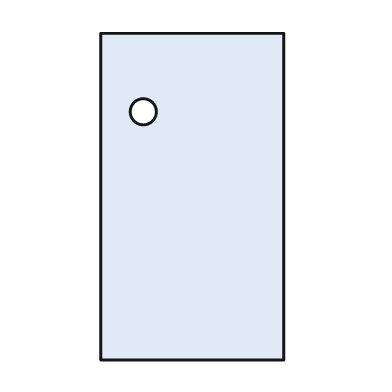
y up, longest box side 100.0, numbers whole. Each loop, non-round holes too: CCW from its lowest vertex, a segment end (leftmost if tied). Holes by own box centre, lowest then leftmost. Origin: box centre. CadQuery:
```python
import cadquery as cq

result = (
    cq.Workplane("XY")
    .moveTo(-28.0, -50.0)
    .lineTo(28.0, -50.0)
    .lineTo(28.0, 50.0)
    .lineTo(-28.0, 50.0)
    .close()
    .moveTo(-15.0, 26.0)
    .circle(4.0)
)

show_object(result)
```